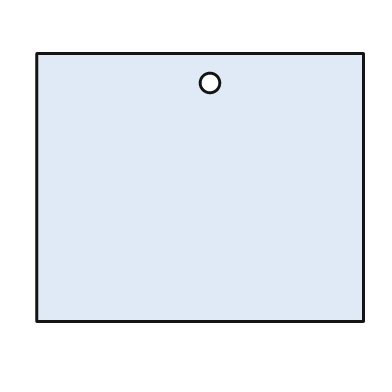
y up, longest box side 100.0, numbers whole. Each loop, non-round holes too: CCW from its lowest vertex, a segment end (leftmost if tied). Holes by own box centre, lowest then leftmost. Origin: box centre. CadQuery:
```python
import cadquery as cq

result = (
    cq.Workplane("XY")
    .moveTo(-50.0, -41.0)
    .lineTo(50.0, -41.0)
    .lineTo(50.0, 41.0)
    .lineTo(-50.0, 41.0)
    .close()
    .moveTo(3.0, 32.0)
    .circle(3.0)
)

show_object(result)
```